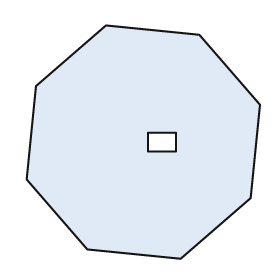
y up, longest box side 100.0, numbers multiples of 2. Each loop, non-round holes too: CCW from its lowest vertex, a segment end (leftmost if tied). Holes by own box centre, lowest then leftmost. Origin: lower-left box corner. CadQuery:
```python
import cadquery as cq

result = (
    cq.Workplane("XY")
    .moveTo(66.0, 0.0)
    .lineTo(96.0, 26.0)
    .lineTo(100.0, 66.0)
    .lineTo(74.0, 96.0)
    .lineTo(34.0, 100.0)
    .lineTo(4.0, 74.0)
    .lineTo(0.0, 34.0)
    .lineTo(26.0, 4.0)
    .close()
    .moveTo(52.0, 46.0)
    .lineTo(64.0, 46.0)
    .lineTo(64.0, 54.0)
    .lineTo(52.0, 54.0)
    .close()
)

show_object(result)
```